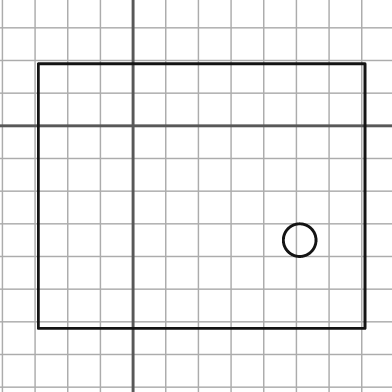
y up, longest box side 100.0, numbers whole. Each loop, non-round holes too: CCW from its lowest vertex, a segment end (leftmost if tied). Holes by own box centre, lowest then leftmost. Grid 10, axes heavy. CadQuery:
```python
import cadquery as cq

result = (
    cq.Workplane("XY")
    .moveTo(-29.0, -62.0)
    .lineTo(71.0, -62.0)
    .lineTo(71.0, 19.0)
    .lineTo(-29.0, 19.0)
    .close()
    .moveTo(51.0, -35.0)
    .circle(5.0)
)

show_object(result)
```